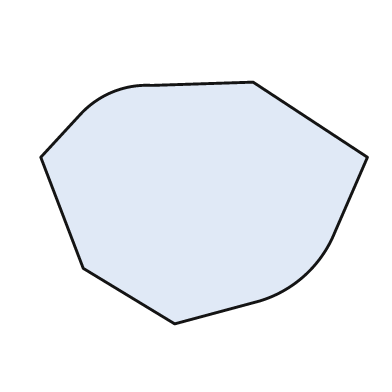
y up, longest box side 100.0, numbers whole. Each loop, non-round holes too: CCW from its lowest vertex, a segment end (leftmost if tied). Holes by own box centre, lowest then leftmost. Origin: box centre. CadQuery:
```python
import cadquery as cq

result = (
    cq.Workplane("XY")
    .moveTo(-9.0, -37.0)
    .lineTo(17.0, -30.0)
    .threePointArc((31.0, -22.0), (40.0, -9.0))
    .lineTo(50.0, 14.0)
    .lineTo(15.0, 37.0)
    .lineTo(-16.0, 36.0)
    .threePointArc((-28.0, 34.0), (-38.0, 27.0))
    .lineTo(-50.0, 14.0)
    .lineTo(-37.0, -20.0)
    .close()
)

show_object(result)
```